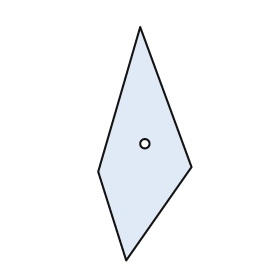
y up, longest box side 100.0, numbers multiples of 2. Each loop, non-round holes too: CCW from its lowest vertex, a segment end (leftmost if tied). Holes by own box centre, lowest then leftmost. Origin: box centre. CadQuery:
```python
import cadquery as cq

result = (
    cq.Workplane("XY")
    .moveTo(-8.0, -50.0)
    .lineTo(20.0, -10.0)
    .lineTo(-2.0, 50.0)
    .lineTo(-20.0, -12.0)
    .close()
    .moveTo(0.0, 0.0)
    .circle(2.0)
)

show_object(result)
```